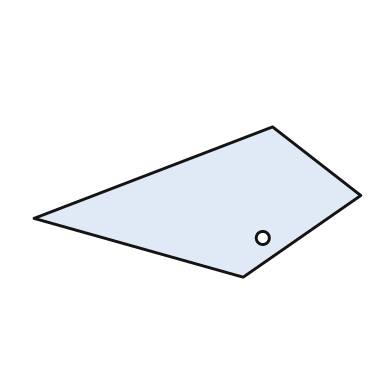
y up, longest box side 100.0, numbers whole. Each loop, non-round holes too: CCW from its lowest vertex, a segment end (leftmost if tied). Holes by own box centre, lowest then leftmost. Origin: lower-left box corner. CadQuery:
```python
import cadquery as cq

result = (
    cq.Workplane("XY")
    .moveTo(64.0, 0.0)
    .lineTo(100.0, 25.0)
    .lineTo(73.0, 46.0)
    .lineTo(0.0, 18.0)
    .close()
    .moveTo(70.0, 12.0)
    .circle(2.0)
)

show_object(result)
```